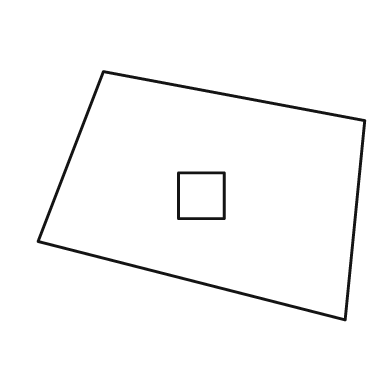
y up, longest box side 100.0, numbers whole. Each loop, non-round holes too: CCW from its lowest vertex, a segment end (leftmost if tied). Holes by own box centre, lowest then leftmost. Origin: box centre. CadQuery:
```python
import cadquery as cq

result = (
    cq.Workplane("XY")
    .moveTo(44.0, -38.0)
    .lineTo(50.0, 23.0)
    .lineTo(-30.0, 38.0)
    .lineTo(-50.0, -14.0)
    .close()
    .moveTo(-7.0, -7.0)
    .lineTo(7.0, -7.0)
    .lineTo(7.0, 7.0)
    .lineTo(-7.0, 7.0)
    .close()
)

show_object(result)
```